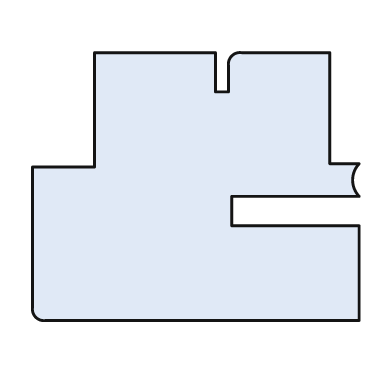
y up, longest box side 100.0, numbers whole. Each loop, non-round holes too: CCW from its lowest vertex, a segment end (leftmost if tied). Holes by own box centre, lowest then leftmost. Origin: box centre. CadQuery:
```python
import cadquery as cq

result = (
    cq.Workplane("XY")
    .moveTo(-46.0, -41.0)
    .lineTo(50.0, -41.0)
    .lineTo(50.0, -12.0)
    .lineTo(11.0, -12.0)
    .lineTo(11.0, -3.0)
    .lineTo(50.0, -3.0)
    .threePointArc((48.0, 2.0), (50.0, 7.0))
    .lineTo(41.0, 7.0)
    .lineTo(41.0, 41.0)
    .lineTo(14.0, 41.0)
    .threePointArc((11.0, 40.0), (10.0, 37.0))
    .lineTo(10.0, 29.0)
    .lineTo(6.0, 29.0)
    .lineTo(6.0, 41.0)
    .lineTo(-31.0, 41.0)
    .lineTo(-31.0, 6.0)
    .lineTo(-50.0, 6.0)
    .lineTo(-50.0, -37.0)
    .threePointArc((-49.0, -40.0), (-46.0, -41.0))
    .close()
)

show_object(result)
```